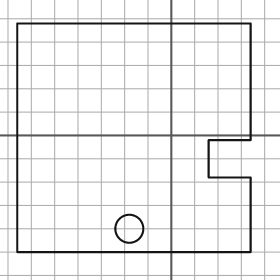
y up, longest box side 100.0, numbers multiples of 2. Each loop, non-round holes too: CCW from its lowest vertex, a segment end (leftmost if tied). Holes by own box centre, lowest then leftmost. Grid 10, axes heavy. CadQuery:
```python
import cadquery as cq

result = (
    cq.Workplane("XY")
    .moveTo(-66.0, -50.0)
    .lineTo(34.0, -50.0)
    .lineTo(34.0, -18.0)
    .lineTo(16.0, -18.0)
    .lineTo(16.0, -2.0)
    .lineTo(34.0, -2.0)
    .lineTo(34.0, 48.0)
    .lineTo(-66.0, 48.0)
    .close()
    .moveTo(-18.0, -40.0)
    .circle(6.0)
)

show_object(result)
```